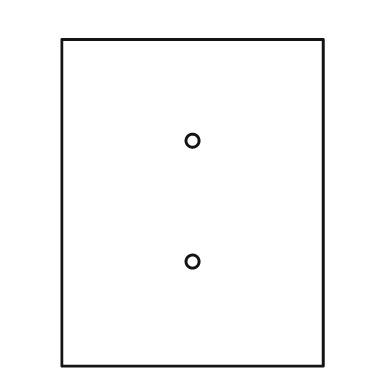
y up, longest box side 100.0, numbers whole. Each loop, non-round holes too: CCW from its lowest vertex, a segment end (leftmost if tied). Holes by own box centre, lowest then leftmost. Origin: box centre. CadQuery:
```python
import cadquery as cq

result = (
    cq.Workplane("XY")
    .moveTo(-40.0, -50.0)
    .lineTo(40.0, -50.0)
    .lineTo(40.0, 50.0)
    .lineTo(-40.0, 50.0)
    .close()
    .moveTo(0.0, -18.0)
    .circle(2.0)
    .moveTo(0.0, 19.0)
    .circle(2.0)
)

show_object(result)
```